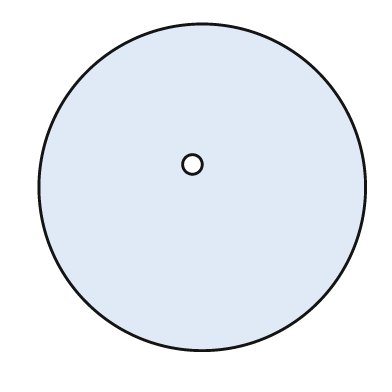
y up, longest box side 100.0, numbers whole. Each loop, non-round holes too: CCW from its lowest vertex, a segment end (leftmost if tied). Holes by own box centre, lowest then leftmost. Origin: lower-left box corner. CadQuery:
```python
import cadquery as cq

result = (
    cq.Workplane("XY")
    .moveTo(50.0, 50.0)
    .circle(50.0)
    .moveTo(47.0, 57.0)
    .circle(3.0)
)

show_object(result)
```